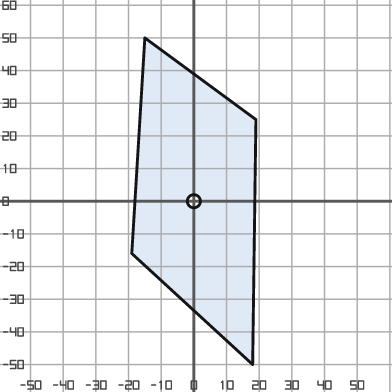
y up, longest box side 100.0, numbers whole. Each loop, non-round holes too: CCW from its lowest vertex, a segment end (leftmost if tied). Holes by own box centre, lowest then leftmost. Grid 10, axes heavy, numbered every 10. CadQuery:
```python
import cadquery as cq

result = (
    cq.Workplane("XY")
    .moveTo(18.0, -50.0)
    .lineTo(19.0, 25.0)
    .lineTo(-15.0, 50.0)
    .lineTo(-19.0, -16.0)
    .close()
    .moveTo(0.0, 0.0)
    .circle(2.0)
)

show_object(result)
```